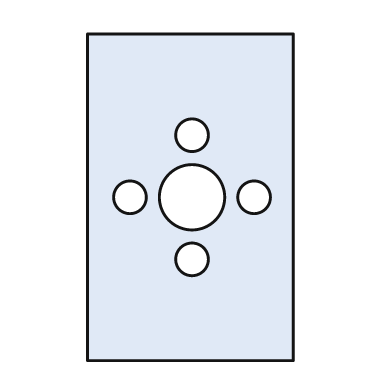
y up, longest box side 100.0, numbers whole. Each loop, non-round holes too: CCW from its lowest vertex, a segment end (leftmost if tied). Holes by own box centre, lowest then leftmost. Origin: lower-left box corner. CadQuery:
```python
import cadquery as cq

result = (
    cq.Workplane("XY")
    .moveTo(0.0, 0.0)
    .lineTo(63.0, 0.0)
    .lineTo(63.0, 100.0)
    .lineTo(0.0, 100.0)
    .close()
    .moveTo(32.0, 31.0)
    .circle(5.0)
    .moveTo(13.0, 50.0)
    .circle(5.0)
    .moveTo(32.0, 50.0)
    .circle(10.0)
    .moveTo(51.0, 50.0)
    .circle(5.0)
    .moveTo(32.0, 69.0)
    .circle(5.0)
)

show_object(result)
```